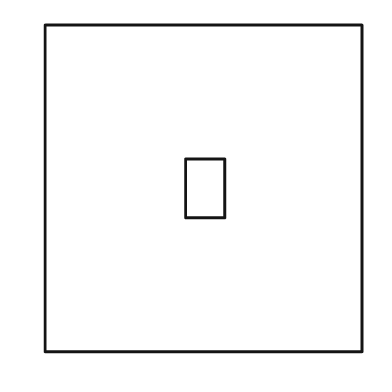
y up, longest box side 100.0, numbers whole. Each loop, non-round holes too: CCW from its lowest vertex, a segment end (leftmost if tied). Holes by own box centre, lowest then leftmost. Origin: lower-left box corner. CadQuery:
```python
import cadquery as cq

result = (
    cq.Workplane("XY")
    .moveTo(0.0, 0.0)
    .lineTo(97.0, 0.0)
    .lineTo(97.0, 100.0)
    .lineTo(0.0, 100.0)
    .close()
    .moveTo(43.0, 41.0)
    .lineTo(55.0, 41.0)
    .lineTo(55.0, 59.0)
    .lineTo(43.0, 59.0)
    .close()
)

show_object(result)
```